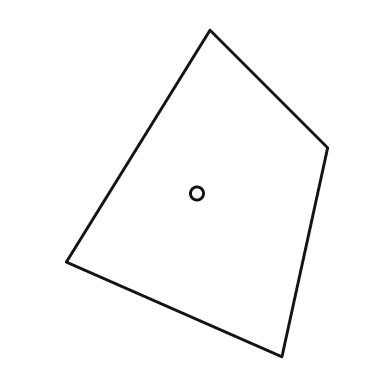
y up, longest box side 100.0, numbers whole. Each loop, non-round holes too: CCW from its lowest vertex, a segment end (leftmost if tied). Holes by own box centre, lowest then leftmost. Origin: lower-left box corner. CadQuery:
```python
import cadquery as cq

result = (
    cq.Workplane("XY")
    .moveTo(66.0, 0.0)
    .lineTo(80.0, 64.0)
    .lineTo(44.0, 100.0)
    .lineTo(0.0, 29.0)
    .close()
    .moveTo(40.0, 50.0)
    .circle(2.0)
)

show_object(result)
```